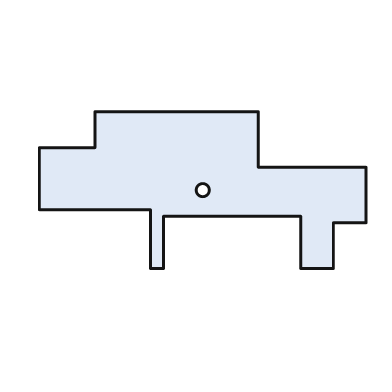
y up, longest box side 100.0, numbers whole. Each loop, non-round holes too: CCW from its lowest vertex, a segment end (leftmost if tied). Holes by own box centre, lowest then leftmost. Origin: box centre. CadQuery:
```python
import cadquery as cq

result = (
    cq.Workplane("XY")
    .moveTo(-16.0, -24.0)
    .lineTo(-12.0, -24.0)
    .lineTo(-12.0, -8.0)
    .lineTo(30.0, -8.0)
    .lineTo(30.0, -24.0)
    .lineTo(40.0, -24.0)
    .lineTo(40.0, -10.0)
    .lineTo(50.0, -10.0)
    .lineTo(50.0, 7.0)
    .lineTo(17.0, 7.0)
    .lineTo(17.0, 24.0)
    .lineTo(-33.0, 24.0)
    .lineTo(-33.0, 13.0)
    .lineTo(-50.0, 13.0)
    .lineTo(-50.0, -6.0)
    .lineTo(-16.0, -6.0)
    .close()
    .moveTo(0.0, 0.0)
    .circle(2.0)
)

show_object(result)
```